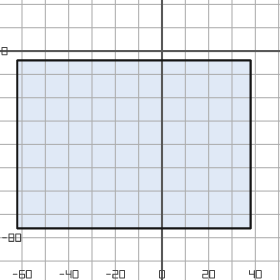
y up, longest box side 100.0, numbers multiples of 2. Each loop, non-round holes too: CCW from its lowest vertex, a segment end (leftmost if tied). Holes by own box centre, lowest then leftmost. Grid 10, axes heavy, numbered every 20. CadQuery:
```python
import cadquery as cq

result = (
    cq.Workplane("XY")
    .moveTo(-62.0, -76.0)
    .lineTo(38.0, -76.0)
    .lineTo(38.0, -4.0)
    .lineTo(-62.0, -4.0)
    .close()
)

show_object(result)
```